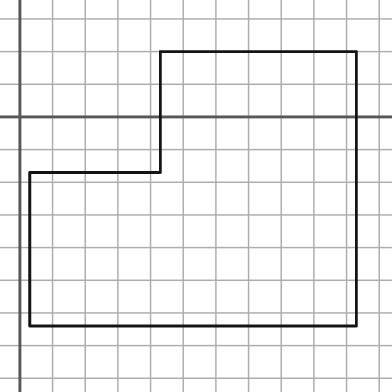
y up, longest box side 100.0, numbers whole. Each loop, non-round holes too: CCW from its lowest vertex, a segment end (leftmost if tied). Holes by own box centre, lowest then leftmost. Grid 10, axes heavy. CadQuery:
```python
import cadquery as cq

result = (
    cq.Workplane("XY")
    .moveTo(3.0, -64.0)
    .lineTo(103.0, -64.0)
    .lineTo(103.0, 20.0)
    .lineTo(43.0, 20.0)
    .lineTo(43.0, -17.0)
    .lineTo(3.0, -17.0)
    .close()
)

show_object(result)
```